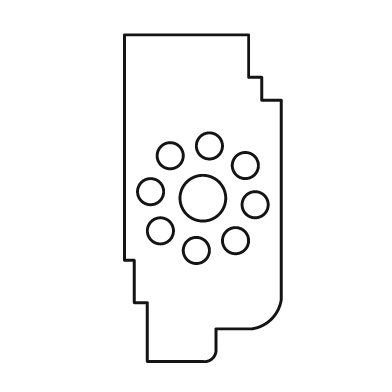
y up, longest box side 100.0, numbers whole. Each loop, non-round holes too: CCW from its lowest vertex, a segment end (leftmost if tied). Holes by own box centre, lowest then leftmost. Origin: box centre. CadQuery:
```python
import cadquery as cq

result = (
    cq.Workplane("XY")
    .moveTo(-17.0, -50.0)
    .lineTo(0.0, -50.0)
    .threePointArc((3.0, -49.0), (4.0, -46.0))
    .lineTo(4.0, -40.0)
    .lineTo(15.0, -40.0)
    .threePointArc((21.0, -37.0), (24.0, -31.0))
    .lineTo(24.0, 30.0)
    .lineTo(18.0, 30.0)
    .lineTo(18.0, 37.0)
    .lineTo(14.0, 37.0)
    .lineTo(14.0, 50.0)
    .lineTo(-24.0, 50.0)
    .lineTo(-24.0, -19.0)
    .lineTo(-21.0, -19.0)
    .lineTo(-21.0, -32.0)
    .lineTo(-17.0, -32.0)
    .close()
    .moveTo(-2.0, -16.0)
    .circle(4.0)
    .moveTo(10.0, -13.0)
    .circle(4.0)
    .moveTo(-13.0, -10.0)
    .circle(4.0)
    .moveTo(16.0, -2.0)
    .circle(4.0)
    .moveTo(0.0, 0.0)
    .circle(7.0)
    .moveTo(-16.0, 2.0)
    .circle(4.0)
    .moveTo(13.0, 10.0)
    .circle(4.0)
    .moveTo(-10.0, 13.0)
    .circle(4.0)
    .moveTo(2.0, 16.0)
    .circle(4.0)
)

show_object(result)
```